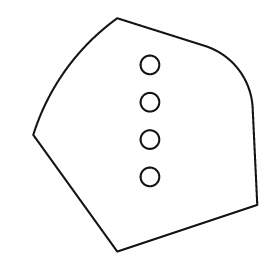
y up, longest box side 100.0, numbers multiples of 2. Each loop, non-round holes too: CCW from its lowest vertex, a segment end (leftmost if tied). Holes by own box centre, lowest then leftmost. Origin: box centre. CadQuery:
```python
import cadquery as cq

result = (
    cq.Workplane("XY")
    .moveTo(-12.0, -50.0)
    .lineTo(48.0, -30.0)
    .lineTo(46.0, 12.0)
    .threePointArc((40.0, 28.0), (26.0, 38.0))
    .lineTo(-12.0, 50.0)
    .threePointArc((-34.0, 28.0), (-48.0, 0.0))
    .close()
    .moveTo(2.0, -18.0)
    .circle(4.0)
    .moveTo(2.0, -2.0)
    .circle(4.0)
    .moveTo(2.0, 14.0)
    .circle(4.0)
    .moveTo(2.0, 30.0)
    .circle(4.0)
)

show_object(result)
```